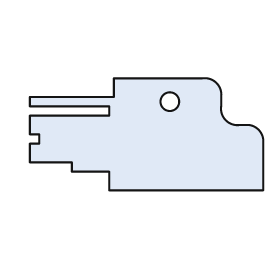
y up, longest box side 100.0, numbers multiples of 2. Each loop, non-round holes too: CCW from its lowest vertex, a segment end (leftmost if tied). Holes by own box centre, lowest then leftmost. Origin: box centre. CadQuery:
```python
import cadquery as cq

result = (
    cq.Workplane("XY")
    .moveTo(-16.0, -24.0)
    .lineTo(50.0, -24.0)
    .lineTo(50.0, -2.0)
    .threePointArc((48.0, 2.0), (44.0, 4.0))
    .lineTo(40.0, 4.0)
    .threePointArc((34.0, 6.0), (32.0, 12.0))
    .lineTo(32.0, 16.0)
    .threePointArc((30.0, 22.0), (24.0, 24.0))
    .lineTo(-14.0, 24.0)
    .lineTo(-14.0, 16.0)
    .lineTo(-50.0, 16.0)
    .lineTo(-50.0, 12.0)
    .lineTo(-16.0, 12.0)
    .lineTo(-16.0, 8.0)
    .lineTo(-50.0, 8.0)
    .lineTo(-50.0, 0.0)
    .lineTo(-46.0, 0.0)
    .lineTo(-46.0, -4.0)
    .lineTo(-50.0, -4.0)
    .lineTo(-50.0, -12.0)
    .lineTo(-32.0, -12.0)
    .lineTo(-32.0, -16.0)
    .lineTo(-16.0, -16.0)
    .close()
    .moveTo(10.0, 14.0)
    .circle(4.0)
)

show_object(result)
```